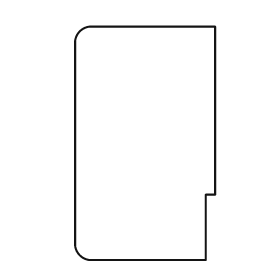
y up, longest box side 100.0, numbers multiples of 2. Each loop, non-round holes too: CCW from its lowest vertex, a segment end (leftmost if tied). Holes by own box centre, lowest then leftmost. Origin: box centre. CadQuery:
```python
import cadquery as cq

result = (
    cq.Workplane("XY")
    .moveTo(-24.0, -50.0)
    .lineTo(26.0, -50.0)
    .lineTo(26.0, -22.0)
    .lineTo(30.0, -22.0)
    .lineTo(30.0, 50.0)
    .lineTo(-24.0, 50.0)
    .threePointArc((-28.0, 48.0), (-30.0, 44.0))
    .lineTo(-30.0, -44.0)
    .threePointArc((-28.0, -48.0), (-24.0, -50.0))
    .close()
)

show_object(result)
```